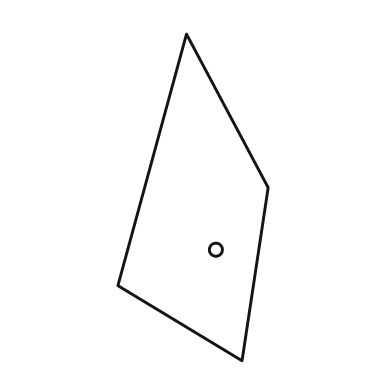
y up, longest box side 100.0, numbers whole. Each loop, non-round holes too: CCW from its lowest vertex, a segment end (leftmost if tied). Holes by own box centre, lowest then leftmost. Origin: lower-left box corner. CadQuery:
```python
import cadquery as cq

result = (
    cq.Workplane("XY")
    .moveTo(38.0, 0.0)
    .lineTo(46.0, 53.0)
    .lineTo(21.0, 100.0)
    .lineTo(0.0, 23.0)
    .close()
    .moveTo(30.0, 34.0)
    .circle(2.0)
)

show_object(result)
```